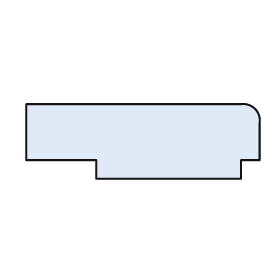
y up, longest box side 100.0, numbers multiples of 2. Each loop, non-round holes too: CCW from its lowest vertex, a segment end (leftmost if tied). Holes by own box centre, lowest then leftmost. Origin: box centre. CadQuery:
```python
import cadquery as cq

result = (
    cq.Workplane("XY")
    .moveTo(-20.0, -16.0)
    .lineTo(42.0, -16.0)
    .lineTo(42.0, -8.0)
    .lineTo(50.0, -8.0)
    .lineTo(50.0, 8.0)
    .threePointArc((48.0, 14.0), (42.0, 16.0))
    .lineTo(-50.0, 16.0)
    .lineTo(-50.0, -8.0)
    .lineTo(-20.0, -8.0)
    .close()
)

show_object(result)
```